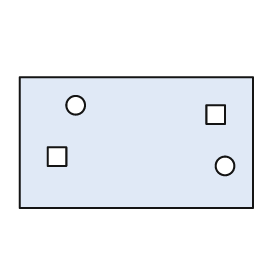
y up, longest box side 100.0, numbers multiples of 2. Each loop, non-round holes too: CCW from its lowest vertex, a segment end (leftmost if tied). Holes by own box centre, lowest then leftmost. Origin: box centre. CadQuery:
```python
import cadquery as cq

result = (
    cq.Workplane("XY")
    .moveTo(-50.0, -28.0)
    .lineTo(50.0, -28.0)
    .lineTo(50.0, 28.0)
    .lineTo(-50.0, 28.0)
    .close()
    .moveTo(38.0, -10.0)
    .circle(4.0)
    .moveTo(-38.0, -10.0)
    .lineTo(-30.0, -10.0)
    .lineTo(-30.0, -2.0)
    .lineTo(-38.0, -2.0)
    .close()
    .moveTo(30.0, 8.0)
    .lineTo(38.0, 8.0)
    .lineTo(38.0, 16.0)
    .lineTo(30.0, 16.0)
    .close()
    .moveTo(-26.0, 16.0)
    .circle(4.0)
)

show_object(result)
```